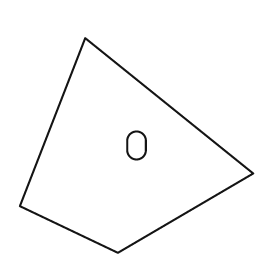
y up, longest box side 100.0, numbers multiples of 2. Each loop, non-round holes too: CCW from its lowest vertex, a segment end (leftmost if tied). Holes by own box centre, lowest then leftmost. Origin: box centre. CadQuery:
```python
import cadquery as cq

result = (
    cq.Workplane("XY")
    .moveTo(-8.0, -46.0)
    .lineTo(50.0, -12.0)
    .lineTo(-22.0, 46.0)
    .lineTo(-50.0, -26.0)
    .close()
    .moveTo(-4.0, -2.0)
    .threePointArc((0.0, -6.0), (4.0, -2.0))
    .lineTo(4.0, 2.0)
    .threePointArc((0.0, 6.0), (-4.0, 2.0))
    .close()
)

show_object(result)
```